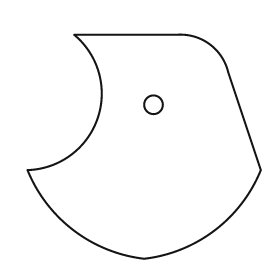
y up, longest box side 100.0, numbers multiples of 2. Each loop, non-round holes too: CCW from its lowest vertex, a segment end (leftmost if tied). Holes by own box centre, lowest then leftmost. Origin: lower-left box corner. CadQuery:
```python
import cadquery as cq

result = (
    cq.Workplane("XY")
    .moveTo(50.0, 0.0)
    .threePointArc((80.0, 12.0), (100.0, 38.0))
    .lineTo(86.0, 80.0)
    .threePointArc((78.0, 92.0), (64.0, 96.0))
    .lineTo(20.0, 96.0)
    .threePointArc((30.0, 60.0), (0.0, 38.0))
    .threePointArc((20.0, 12.0), (50.0, 0.0))
    .close()
    .moveTo(54.0, 66.0)
    .circle(4.0)
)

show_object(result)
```